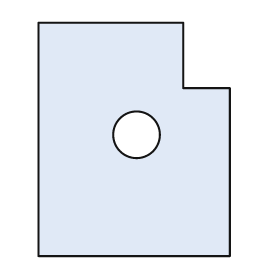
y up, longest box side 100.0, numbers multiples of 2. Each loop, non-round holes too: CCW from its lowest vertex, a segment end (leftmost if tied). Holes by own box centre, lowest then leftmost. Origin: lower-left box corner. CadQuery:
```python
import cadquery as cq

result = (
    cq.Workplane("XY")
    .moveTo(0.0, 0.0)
    .lineTo(82.0, 0.0)
    .lineTo(82.0, 72.0)
    .lineTo(62.0, 72.0)
    .lineTo(62.0, 100.0)
    .lineTo(0.0, 100.0)
    .close()
    .moveTo(42.0, 52.0)
    .circle(10.0)
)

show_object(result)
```